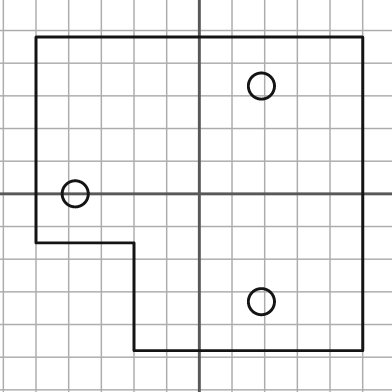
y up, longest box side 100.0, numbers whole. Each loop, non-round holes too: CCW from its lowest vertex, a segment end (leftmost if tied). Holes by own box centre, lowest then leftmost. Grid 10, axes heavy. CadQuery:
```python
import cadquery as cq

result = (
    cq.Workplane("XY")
    .moveTo(-20.0, -48.0)
    .lineTo(50.0, -48.0)
    .lineTo(50.0, 48.0)
    .lineTo(-50.0, 48.0)
    .lineTo(-50.0, -15.0)
    .lineTo(-20.0, -15.0)
    .close()
    .moveTo(19.0, -33.0)
    .circle(4.0)
    .moveTo(-38.0, 0.0)
    .circle(4.0)
    .moveTo(19.0, 33.0)
    .circle(4.0)
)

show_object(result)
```